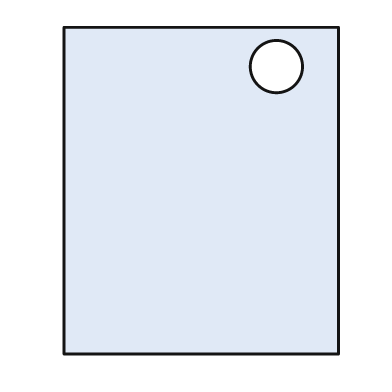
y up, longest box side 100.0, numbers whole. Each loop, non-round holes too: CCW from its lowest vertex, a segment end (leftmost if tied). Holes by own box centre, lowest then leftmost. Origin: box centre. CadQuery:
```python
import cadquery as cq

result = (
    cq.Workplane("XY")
    .moveTo(-42.0, -50.0)
    .lineTo(42.0, -50.0)
    .lineTo(42.0, 50.0)
    .lineTo(-42.0, 50.0)
    .close()
    .moveTo(23.0, 38.0)
    .circle(8.0)
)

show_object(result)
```